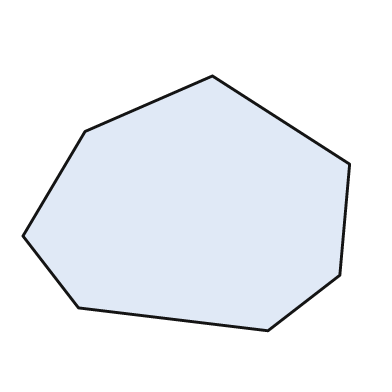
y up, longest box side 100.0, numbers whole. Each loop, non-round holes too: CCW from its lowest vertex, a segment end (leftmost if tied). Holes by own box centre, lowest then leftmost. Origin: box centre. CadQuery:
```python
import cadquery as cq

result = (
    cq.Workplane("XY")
    .moveTo(25.0, -39.0)
    .lineTo(47.0, -22.0)
    .lineTo(50.0, 12.0)
    .lineTo(8.0, 39.0)
    .lineTo(-31.0, 22.0)
    .lineTo(-50.0, -10.0)
    .lineTo(-33.0, -32.0)
    .close()
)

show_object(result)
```